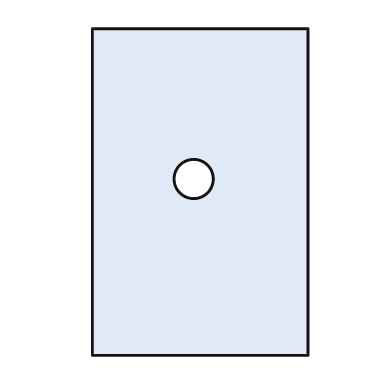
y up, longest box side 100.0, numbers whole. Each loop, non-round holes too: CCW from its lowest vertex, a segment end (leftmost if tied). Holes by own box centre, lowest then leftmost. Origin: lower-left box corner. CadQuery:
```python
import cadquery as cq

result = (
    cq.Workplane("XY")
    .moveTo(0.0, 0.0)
    .lineTo(66.0, 0.0)
    .lineTo(66.0, 100.0)
    .lineTo(0.0, 100.0)
    .close()
    .moveTo(31.0, 54.0)
    .circle(6.0)
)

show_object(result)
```